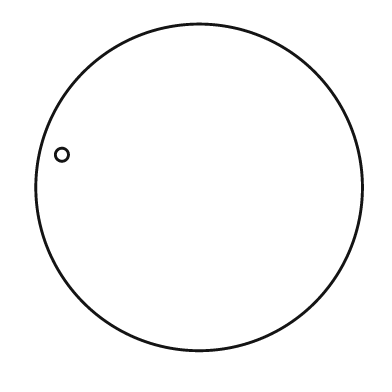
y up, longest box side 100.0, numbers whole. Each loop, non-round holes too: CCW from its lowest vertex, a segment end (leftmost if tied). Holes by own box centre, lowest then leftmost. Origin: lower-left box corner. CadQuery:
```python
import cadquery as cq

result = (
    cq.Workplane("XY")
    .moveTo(50.0, 50.0)
    .circle(50.0)
    .moveTo(8.0, 60.0)
    .circle(2.0)
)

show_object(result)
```